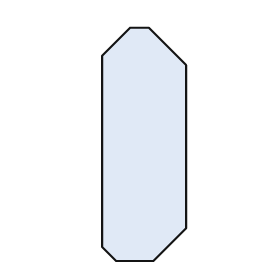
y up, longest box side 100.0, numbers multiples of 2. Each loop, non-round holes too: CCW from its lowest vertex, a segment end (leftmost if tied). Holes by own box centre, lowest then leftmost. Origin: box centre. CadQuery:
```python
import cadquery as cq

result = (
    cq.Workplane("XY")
    .moveTo(-12.0, -50.0)
    .lineTo(4.0, -50.0)
    .lineTo(18.0, -36.0)
    .lineTo(18.0, 34.0)
    .lineTo(2.0, 50.0)
    .lineTo(-6.0, 50.0)
    .lineTo(-18.0, 38.0)
    .lineTo(-18.0, -44.0)
    .close()
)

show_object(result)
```